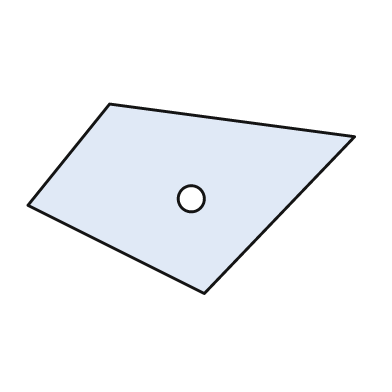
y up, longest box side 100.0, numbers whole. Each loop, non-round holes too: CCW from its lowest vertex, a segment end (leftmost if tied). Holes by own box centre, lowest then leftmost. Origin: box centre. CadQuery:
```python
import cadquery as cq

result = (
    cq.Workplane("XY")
    .moveTo(4.0, -29.0)
    .lineTo(50.0, 19.0)
    .lineTo(-25.0, 29.0)
    .lineTo(-50.0, -2.0)
    .close()
    .moveTo(0.0, 0.0)
    .circle(4.0)
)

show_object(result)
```